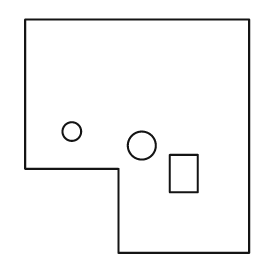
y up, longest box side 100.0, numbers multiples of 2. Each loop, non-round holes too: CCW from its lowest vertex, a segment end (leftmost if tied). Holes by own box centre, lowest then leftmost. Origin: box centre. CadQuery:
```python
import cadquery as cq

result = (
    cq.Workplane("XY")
    .moveTo(-8.0, -50.0)
    .lineTo(48.0, -50.0)
    .lineTo(48.0, 50.0)
    .lineTo(-48.0, 50.0)
    .lineTo(-48.0, -14.0)
    .lineTo(-8.0, -14.0)
    .close()
    .moveTo(14.0, -24.0)
    .lineTo(26.0, -24.0)
    .lineTo(26.0, -8.0)
    .lineTo(14.0, -8.0)
    .close()
    .moveTo(2.0, -4.0)
    .circle(6.0)
    .moveTo(-28.0, 2.0)
    .circle(4.0)
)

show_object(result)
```